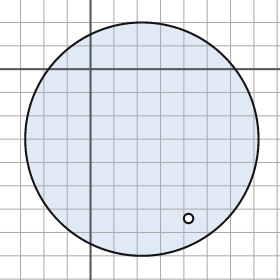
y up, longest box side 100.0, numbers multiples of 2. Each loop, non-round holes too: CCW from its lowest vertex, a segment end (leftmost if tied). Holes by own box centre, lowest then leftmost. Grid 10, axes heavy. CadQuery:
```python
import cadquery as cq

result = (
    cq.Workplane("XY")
    .moveTo(22.0, -30.0)
    .circle(50.0)
    .moveTo(42.0, -64.0)
    .circle(2.0)
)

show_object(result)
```